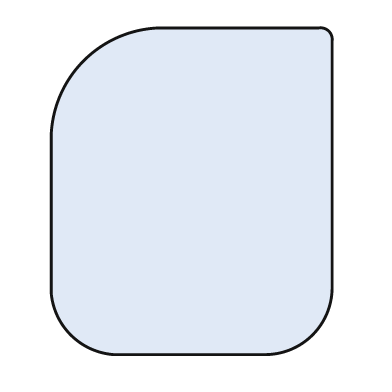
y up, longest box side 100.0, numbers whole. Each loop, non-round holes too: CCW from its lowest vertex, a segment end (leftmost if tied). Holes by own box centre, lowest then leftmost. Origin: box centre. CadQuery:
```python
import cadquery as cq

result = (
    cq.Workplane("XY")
    .moveTo(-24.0, -50.0)
    .lineTo(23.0, -50.0)
    .threePointArc((37.0, -44.0), (43.0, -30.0))
    .lineTo(43.0, 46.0)
    .threePointArc((42.0, 49.0), (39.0, 50.0))
    .lineTo(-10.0, 50.0)
    .threePointArc((-33.0, 40.0), (-43.0, 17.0))
    .lineTo(-43.0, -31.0)
    .threePointArc((-37.0, -44.0), (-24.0, -50.0))
    .close()
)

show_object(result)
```